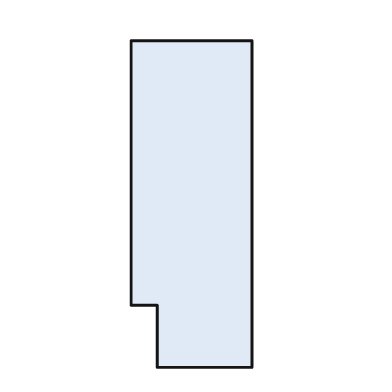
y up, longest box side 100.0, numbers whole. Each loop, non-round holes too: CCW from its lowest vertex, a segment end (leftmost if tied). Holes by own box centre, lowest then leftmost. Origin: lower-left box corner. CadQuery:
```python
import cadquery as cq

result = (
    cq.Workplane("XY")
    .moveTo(8.0, 0.0)
    .lineTo(37.0, 0.0)
    .lineTo(37.0, 100.0)
    .lineTo(0.0, 100.0)
    .lineTo(0.0, 19.0)
    .lineTo(8.0, 19.0)
    .close()
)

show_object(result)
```